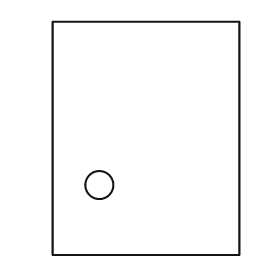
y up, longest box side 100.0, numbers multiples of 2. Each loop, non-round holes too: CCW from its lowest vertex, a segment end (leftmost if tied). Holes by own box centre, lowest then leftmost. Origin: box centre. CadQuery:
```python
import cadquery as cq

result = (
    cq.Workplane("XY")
    .moveTo(-40.0, -50.0)
    .lineTo(40.0, -50.0)
    .lineTo(40.0, 50.0)
    .lineTo(-40.0, 50.0)
    .close()
    .moveTo(-20.0, -20.0)
    .circle(6.0)
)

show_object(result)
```